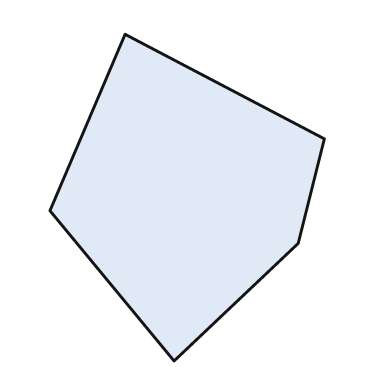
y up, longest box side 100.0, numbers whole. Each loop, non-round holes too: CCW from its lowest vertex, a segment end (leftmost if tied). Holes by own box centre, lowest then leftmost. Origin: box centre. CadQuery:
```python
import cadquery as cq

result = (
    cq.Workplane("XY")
    .moveTo(-4.0, -50.0)
    .lineTo(34.0, -14.0)
    .lineTo(42.0, 18.0)
    .lineTo(-19.0, 50.0)
    .lineTo(-42.0, -4.0)
    .close()
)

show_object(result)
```